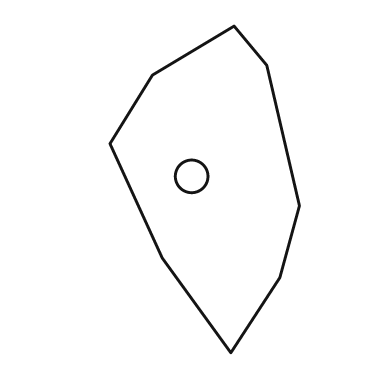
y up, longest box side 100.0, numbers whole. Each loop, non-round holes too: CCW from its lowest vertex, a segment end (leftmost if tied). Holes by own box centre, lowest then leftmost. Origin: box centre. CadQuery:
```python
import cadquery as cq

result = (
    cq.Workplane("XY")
    .moveTo(8.0, -50.0)
    .lineTo(23.0, -27.0)
    .lineTo(29.0, -5.0)
    .lineTo(19.0, 38.0)
    .lineTo(9.0, 50.0)
    .lineTo(-16.0, 35.0)
    .lineTo(-29.0, 14.0)
    .lineTo(-13.0, -21.0)
    .close()
    .moveTo(-4.0, 4.0)
    .circle(5.0)
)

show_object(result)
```